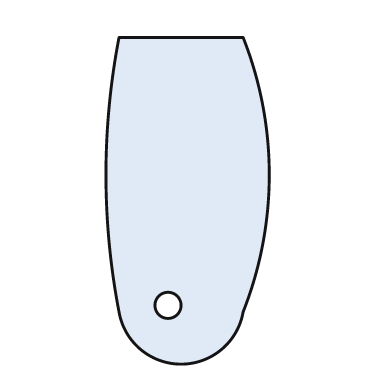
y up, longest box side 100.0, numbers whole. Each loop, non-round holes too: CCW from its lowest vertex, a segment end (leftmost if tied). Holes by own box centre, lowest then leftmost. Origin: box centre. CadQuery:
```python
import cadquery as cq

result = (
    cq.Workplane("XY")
    .moveTo(-21.0, -34.0)
    .threePointArc((-2.0, -50.0), (17.0, -34.0))
    .threePointArc((25.0, 8.0), (17.0, 50.0))
    .lineTo(-21.0, 50.0)
    .threePointArc((-25.0, 8.0), (-21.0, -34.0))
    .close()
    .moveTo(-6.0, -32.0)
    .circle(4.0)
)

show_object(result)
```